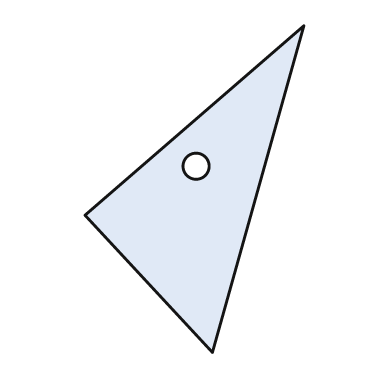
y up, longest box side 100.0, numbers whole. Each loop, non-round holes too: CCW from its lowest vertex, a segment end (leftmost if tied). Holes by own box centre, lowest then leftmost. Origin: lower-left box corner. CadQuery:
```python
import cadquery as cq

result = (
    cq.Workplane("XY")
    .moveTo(39.0, 0.0)
    .lineTo(67.0, 100.0)
    .lineTo(0.0, 42.0)
    .close()
    .moveTo(34.0, 57.0)
    .circle(4.0)
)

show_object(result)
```